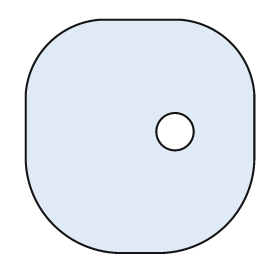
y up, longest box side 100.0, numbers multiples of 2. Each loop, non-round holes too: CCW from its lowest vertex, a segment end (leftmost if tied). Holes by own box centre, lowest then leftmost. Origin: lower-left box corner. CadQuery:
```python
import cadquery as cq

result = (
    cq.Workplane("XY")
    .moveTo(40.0, 0.0)
    .lineTo(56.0, 0.0)
    .threePointArc((86.0, 12.0), (98.0, 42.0))
    .lineTo(98.0, 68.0)
    .threePointArc((88.0, 90.0), (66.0, 100.0))
    .lineTo(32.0, 100.0)
    .threePointArc((10.0, 90.0), (0.0, 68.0))
    .lineTo(0.0, 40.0)
    .threePointArc((12.0, 12.0), (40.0, 0.0))
    .close()
    .moveTo(64.0, 52.0)
    .circle(8.0)
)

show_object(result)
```